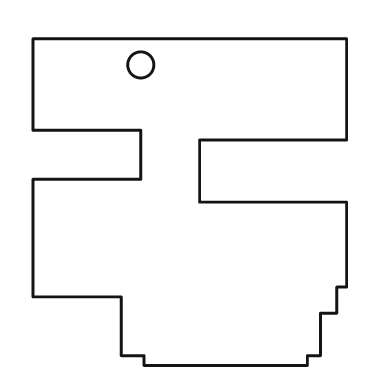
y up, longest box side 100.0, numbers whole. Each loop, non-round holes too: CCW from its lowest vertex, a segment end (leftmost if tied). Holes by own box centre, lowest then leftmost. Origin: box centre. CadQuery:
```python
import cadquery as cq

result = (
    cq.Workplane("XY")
    .moveTo(-14.0, -50.0)
    .lineTo(36.0, -50.0)
    .lineTo(36.0, -47.0)
    .lineTo(40.0, -47.0)
    .lineTo(40.0, -34.0)
    .lineTo(45.0, -34.0)
    .lineTo(45.0, -26.0)
    .lineTo(48.0, -26.0)
    .lineTo(48.0, 0.0)
    .lineTo(3.0, 0.0)
    .lineTo(3.0, 19.0)
    .lineTo(48.0, 19.0)
    .lineTo(48.0, 50.0)
    .lineTo(-48.0, 50.0)
    .lineTo(-48.0, 22.0)
    .lineTo(-15.0, 22.0)
    .lineTo(-15.0, 7.0)
    .lineTo(-48.0, 7.0)
    .lineTo(-48.0, -29.0)
    .lineTo(-21.0, -29.0)
    .lineTo(-21.0, -47.0)
    .lineTo(-14.0, -47.0)
    .close()
    .moveTo(-15.0, 42.0)
    .circle(4.0)
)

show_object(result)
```